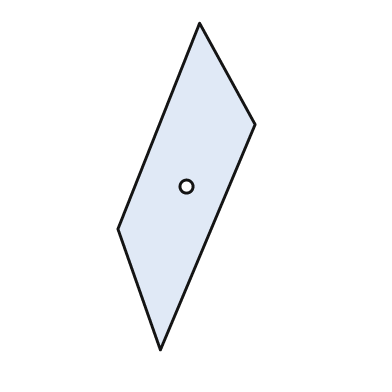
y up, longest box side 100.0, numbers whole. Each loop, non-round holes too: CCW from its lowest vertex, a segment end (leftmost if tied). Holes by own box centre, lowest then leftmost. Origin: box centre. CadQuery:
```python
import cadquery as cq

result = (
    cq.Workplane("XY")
    .moveTo(-8.0, -50.0)
    .lineTo(21.0, 19.0)
    .lineTo(4.0, 50.0)
    .lineTo(-21.0, -13.0)
    .close()
    .moveTo(0.0, 0.0)
    .circle(2.0)
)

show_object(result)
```